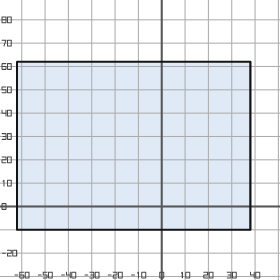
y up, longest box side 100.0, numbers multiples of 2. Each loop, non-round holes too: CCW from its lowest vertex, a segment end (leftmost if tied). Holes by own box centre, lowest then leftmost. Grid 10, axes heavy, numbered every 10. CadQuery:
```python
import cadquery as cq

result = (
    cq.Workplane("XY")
    .moveTo(-62.0, -10.0)
    .lineTo(38.0, -10.0)
    .lineTo(38.0, 62.0)
    .lineTo(-62.0, 62.0)
    .close()
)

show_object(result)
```